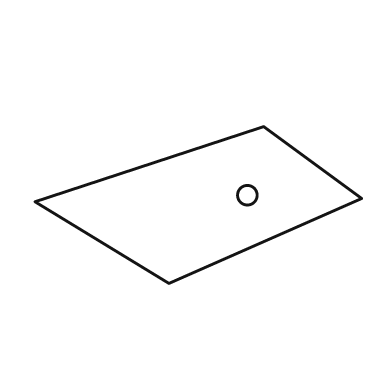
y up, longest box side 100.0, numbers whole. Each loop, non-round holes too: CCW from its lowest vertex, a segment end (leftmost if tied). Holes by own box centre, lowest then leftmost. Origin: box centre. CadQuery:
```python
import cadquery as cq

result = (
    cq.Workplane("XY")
    .moveTo(-9.0, -24.0)
    .lineTo(50.0, 2.0)
    .lineTo(20.0, 24.0)
    .lineTo(-50.0, 1.0)
    .close()
    .moveTo(15.0, 3.0)
    .circle(3.0)
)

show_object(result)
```